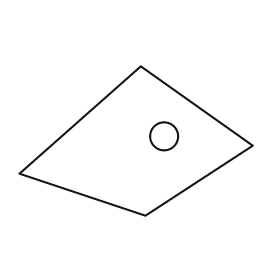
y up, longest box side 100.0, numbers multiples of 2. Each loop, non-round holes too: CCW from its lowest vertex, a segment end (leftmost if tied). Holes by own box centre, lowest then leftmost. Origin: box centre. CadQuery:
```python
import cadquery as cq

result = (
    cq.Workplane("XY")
    .moveTo(4.0, -32.0)
    .lineTo(50.0, -2.0)
    .lineTo(2.0, 32.0)
    .lineTo(-50.0, -14.0)
    .close()
    .moveTo(12.0, 2.0)
    .circle(6.0)
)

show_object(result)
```